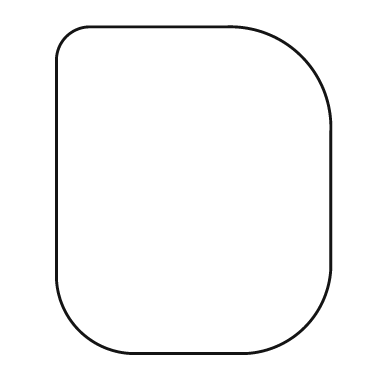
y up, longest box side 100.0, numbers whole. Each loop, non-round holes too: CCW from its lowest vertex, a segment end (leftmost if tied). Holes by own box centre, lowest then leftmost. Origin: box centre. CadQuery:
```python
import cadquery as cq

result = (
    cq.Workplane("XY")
    .moveTo(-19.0, -50.0)
    .lineTo(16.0, -50.0)
    .threePointArc((34.0, -42.0), (42.0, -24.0))
    .lineTo(42.0, 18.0)
    .threePointArc((33.0, 41.0), (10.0, 50.0))
    .lineTo(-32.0, 50.0)
    .threePointArc((-39.0, 47.0), (-42.0, 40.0))
    .lineTo(-42.0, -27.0)
    .threePointArc((-35.0, -43.0), (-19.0, -50.0))
    .close()
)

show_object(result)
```